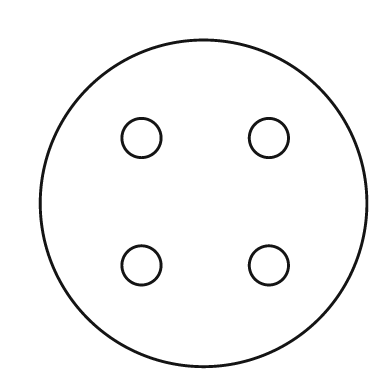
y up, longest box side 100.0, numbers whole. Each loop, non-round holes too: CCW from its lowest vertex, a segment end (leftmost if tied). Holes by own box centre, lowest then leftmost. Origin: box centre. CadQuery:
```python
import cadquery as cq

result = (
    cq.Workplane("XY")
    .moveTo(0.0, 0.0)
    .circle(50.0)
    .moveTo(-19.0, -19.0)
    .circle(6.0)
    .moveTo(20.0, -19.0)
    .circle(6.0)
    .moveTo(-19.0, 20.0)
    .circle(6.0)
    .moveTo(20.0, 20.0)
    .circle(6.0)
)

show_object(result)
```